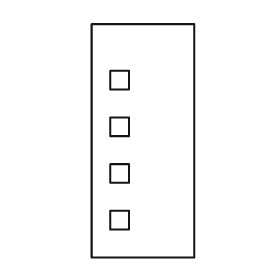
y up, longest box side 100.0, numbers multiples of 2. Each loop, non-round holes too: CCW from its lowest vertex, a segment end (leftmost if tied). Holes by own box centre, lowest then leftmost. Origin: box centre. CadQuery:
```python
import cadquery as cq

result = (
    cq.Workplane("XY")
    .moveTo(-22.0, -50.0)
    .lineTo(22.0, -50.0)
    .lineTo(22.0, 50.0)
    .lineTo(-22.0, 50.0)
    .close()
    .moveTo(-14.0, -38.0)
    .lineTo(-6.0, -38.0)
    .lineTo(-6.0, -30.0)
    .lineTo(-14.0, -30.0)
    .close()
    .moveTo(-14.0, -18.0)
    .lineTo(-6.0, -18.0)
    .lineTo(-6.0, -10.0)
    .lineTo(-14.0, -10.0)
    .close()
    .moveTo(-14.0, 2.0)
    .lineTo(-6.0, 2.0)
    .lineTo(-6.0, 10.0)
    .lineTo(-14.0, 10.0)
    .close()
    .moveTo(-14.0, 22.0)
    .lineTo(-6.0, 22.0)
    .lineTo(-6.0, 30.0)
    .lineTo(-14.0, 30.0)
    .close()
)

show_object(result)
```